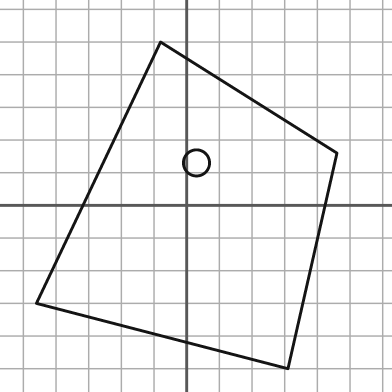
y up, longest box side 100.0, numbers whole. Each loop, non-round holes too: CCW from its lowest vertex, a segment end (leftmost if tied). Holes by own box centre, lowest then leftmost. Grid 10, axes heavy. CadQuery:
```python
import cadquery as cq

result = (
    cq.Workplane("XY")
    .moveTo(31.0, -50.0)
    .lineTo(46.0, 16.0)
    .lineTo(-8.0, 50.0)
    .lineTo(-46.0, -30.0)
    .close()
    .moveTo(3.0, 13.0)
    .circle(4.0)
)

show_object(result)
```